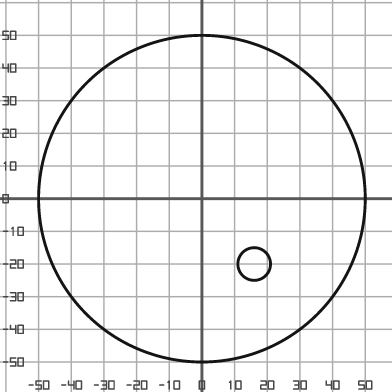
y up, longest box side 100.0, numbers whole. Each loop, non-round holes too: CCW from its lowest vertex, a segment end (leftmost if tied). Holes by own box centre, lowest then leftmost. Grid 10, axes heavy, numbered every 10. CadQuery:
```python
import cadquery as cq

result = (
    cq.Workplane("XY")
    .moveTo(0.0, 0.0)
    .circle(50.0)
    .moveTo(16.0, -20.0)
    .circle(5.0)
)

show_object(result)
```